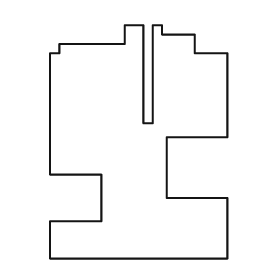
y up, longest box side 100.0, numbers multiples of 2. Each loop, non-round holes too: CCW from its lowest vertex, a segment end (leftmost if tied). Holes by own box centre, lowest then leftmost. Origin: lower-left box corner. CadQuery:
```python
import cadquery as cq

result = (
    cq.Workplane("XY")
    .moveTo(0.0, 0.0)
    .lineTo(76.0, 0.0)
    .lineTo(76.0, 26.0)
    .lineTo(50.0, 26.0)
    .lineTo(50.0, 52.0)
    .lineTo(76.0, 52.0)
    .lineTo(76.0, 88.0)
    .lineTo(62.0, 88.0)
    .lineTo(62.0, 96.0)
    .lineTo(48.0, 96.0)
    .lineTo(48.0, 100.0)
    .lineTo(44.0, 100.0)
    .lineTo(44.0, 58.0)
    .lineTo(40.0, 58.0)
    .lineTo(40.0, 100.0)
    .lineTo(32.0, 100.0)
    .lineTo(32.0, 92.0)
    .lineTo(4.0, 92.0)
    .lineTo(4.0, 88.0)
    .lineTo(0.0, 88.0)
    .lineTo(0.0, 36.0)
    .lineTo(22.0, 36.0)
    .lineTo(22.0, 16.0)
    .lineTo(0.0, 16.0)
    .close()
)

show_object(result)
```